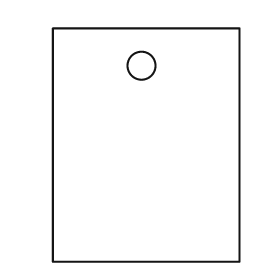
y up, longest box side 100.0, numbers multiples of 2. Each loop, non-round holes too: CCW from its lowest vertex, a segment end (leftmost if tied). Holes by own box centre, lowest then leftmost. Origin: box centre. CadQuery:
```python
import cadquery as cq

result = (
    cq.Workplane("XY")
    .moveTo(-40.0, -50.0)
    .lineTo(40.0, -50.0)
    .lineTo(40.0, 50.0)
    .lineTo(-40.0, 50.0)
    .close()
    .moveTo(-2.0, 34.0)
    .circle(6.0)
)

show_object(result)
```